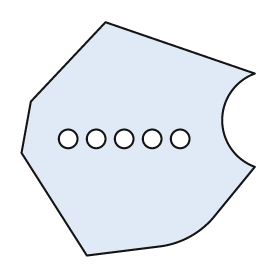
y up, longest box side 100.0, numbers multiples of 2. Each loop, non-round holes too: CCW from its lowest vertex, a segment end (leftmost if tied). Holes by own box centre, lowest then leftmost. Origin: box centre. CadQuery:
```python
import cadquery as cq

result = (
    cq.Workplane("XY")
    .moveTo(-22.0, -50.0)
    .lineTo(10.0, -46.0)
    .threePointArc((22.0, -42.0), (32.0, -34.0))
    .lineTo(50.0, -12.0)
    .threePointArc((36.0, 8.0), (50.0, 28.0))
    .lineTo(-14.0, 50.0)
    .lineTo(-46.0, 16.0)
    .lineTo(-50.0, -6.0)
    .close()
    .moveTo(-30.0, 0.0)
    .circle(4.0)
    .moveTo(-18.0, 0.0)
    .circle(4.0)
    .moveTo(-6.0, 0.0)
    .circle(4.0)
    .moveTo(6.0, 0.0)
    .circle(4.0)
    .moveTo(18.0, 0.0)
    .circle(4.0)
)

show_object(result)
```